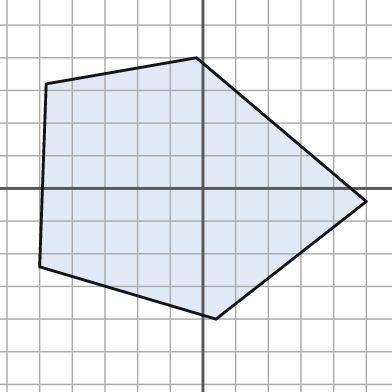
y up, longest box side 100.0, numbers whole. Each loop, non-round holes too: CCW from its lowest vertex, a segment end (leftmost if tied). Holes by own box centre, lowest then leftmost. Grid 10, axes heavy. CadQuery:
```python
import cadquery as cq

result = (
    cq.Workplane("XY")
    .moveTo(4.0, -40.0)
    .lineTo(50.0, -4.0)
    .lineTo(-2.0, 40.0)
    .lineTo(-48.0, 32.0)
    .lineTo(-50.0, -24.0)
    .close()
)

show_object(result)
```